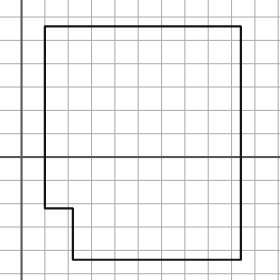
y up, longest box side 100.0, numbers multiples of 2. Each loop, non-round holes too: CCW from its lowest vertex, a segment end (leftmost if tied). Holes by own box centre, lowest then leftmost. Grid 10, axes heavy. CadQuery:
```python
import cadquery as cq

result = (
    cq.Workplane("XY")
    .moveTo(22.0, -44.0)
    .lineTo(94.0, -44.0)
    .lineTo(94.0, 56.0)
    .lineTo(10.0, 56.0)
    .lineTo(10.0, -22.0)
    .lineTo(22.0, -22.0)
    .close()
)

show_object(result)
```